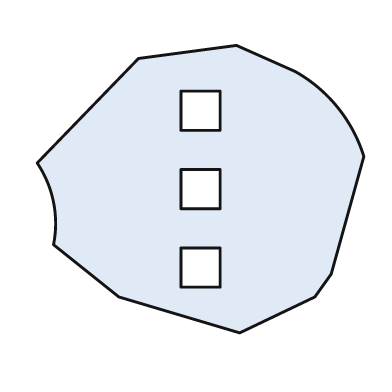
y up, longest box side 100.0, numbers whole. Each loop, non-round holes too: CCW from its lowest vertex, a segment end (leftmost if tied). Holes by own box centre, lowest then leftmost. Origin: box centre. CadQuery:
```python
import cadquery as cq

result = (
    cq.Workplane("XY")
    .moveTo(12.0, -44.0)
    .lineTo(35.0, -33.0)
    .lineTo(40.0, -26.0)
    .lineTo(50.0, 10.0)
    .threePointArc((42.0, 25.0), (29.0, 36.0))
    .lineTo(11.0, 44.0)
    .lineTo(-19.0, 40.0)
    .lineTo(-50.0, 8.0)
    .threePointArc((-45.0, -4.0), (-45.0, -17.0))
    .lineTo(-25.0, -33.0)
    .close()
    .moveTo(-6.0, -30.0)
    .lineTo(6.0, -30.0)
    .lineTo(6.0, -18.0)
    .lineTo(-6.0, -18.0)
    .close()
    .moveTo(-6.0, -6.0)
    .lineTo(6.0, -6.0)
    .lineTo(6.0, 6.0)
    .lineTo(-6.0, 6.0)
    .close()
    .moveTo(-6.0, 18.0)
    .lineTo(6.0, 18.0)
    .lineTo(6.0, 30.0)
    .lineTo(-6.0, 30.0)
    .close()
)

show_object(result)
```